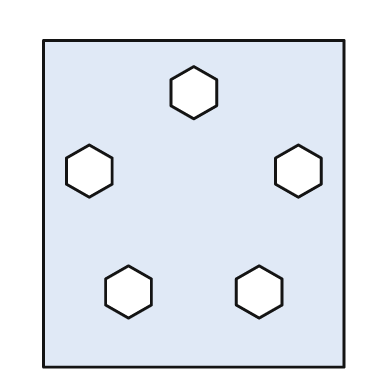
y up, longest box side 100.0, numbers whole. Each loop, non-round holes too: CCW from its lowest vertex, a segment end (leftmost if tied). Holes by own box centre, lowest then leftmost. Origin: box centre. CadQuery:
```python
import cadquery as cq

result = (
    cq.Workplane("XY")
    .moveTo(-46.0, -50.0)
    .lineTo(46.0, -50.0)
    .lineTo(46.0, 50.0)
    .lineTo(-46.0, 50.0)
    .close()
    .moveTo(-20.0, -35.0)
    .lineTo(-13.0, -31.0)
    .lineTo(-13.0, -23.0)
    .lineTo(-20.0, -19.0)
    .lineTo(-27.0, -23.0)
    .lineTo(-27.0, -31.0)
    .close()
    .moveTo(20.0, -35.0)
    .lineTo(27.0, -31.0)
    .lineTo(27.0, -23.0)
    .lineTo(20.0, -19.0)
    .lineTo(13.0, -23.0)
    .lineTo(13.0, -31.0)
    .close()
    .moveTo(-32.0, 2.0)
    .lineTo(-25.0, 6.0)
    .lineTo(-25.0, 14.0)
    .lineTo(-32.0, 18.0)
    .lineTo(-39.0, 14.0)
    .lineTo(-39.0, 6.0)
    .close()
    .moveTo(32.0, 2.0)
    .lineTo(39.0, 6.0)
    .lineTo(39.0, 14.0)
    .lineTo(32.0, 18.0)
    .lineTo(25.0, 14.0)
    .lineTo(25.0, 6.0)
    .close()
    .moveTo(0.0, 26.0)
    .lineTo(7.0, 30.0)
    .lineTo(7.0, 38.0)
    .lineTo(0.0, 42.0)
    .lineTo(-7.0, 38.0)
    .lineTo(-7.0, 30.0)
    .close()
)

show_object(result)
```